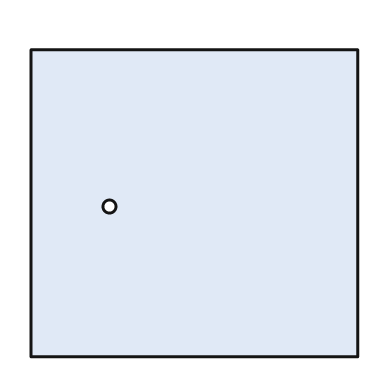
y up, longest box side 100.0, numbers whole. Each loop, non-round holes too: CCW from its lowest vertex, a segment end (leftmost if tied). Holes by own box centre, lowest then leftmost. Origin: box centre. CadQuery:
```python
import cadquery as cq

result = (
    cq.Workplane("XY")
    .moveTo(-50.0, -47.0)
    .lineTo(50.0, -47.0)
    .lineTo(50.0, 47.0)
    .lineTo(-50.0, 47.0)
    .close()
    .moveTo(-26.0, -1.0)
    .circle(2.0)
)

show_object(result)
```